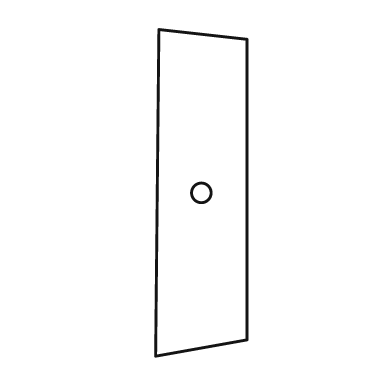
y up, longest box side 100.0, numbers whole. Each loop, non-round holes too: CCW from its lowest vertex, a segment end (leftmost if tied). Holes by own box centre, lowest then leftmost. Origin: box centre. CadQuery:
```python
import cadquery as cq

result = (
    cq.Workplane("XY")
    .moveTo(-14.0, -50.0)
    .lineTo(14.0, -45.0)
    .lineTo(14.0, 47.0)
    .lineTo(-13.0, 50.0)
    .close()
    .moveTo(0.0, 0.0)
    .circle(3.0)
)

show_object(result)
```